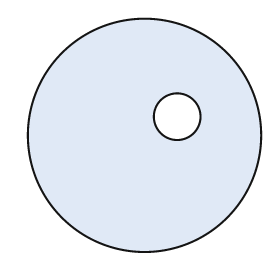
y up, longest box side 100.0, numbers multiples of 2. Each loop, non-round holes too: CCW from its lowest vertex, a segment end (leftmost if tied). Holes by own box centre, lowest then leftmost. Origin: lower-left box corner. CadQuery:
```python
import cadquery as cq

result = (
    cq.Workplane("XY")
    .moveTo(50.0, 50.0)
    .circle(50.0)
    .moveTo(64.0, 58.0)
    .circle(10.0)
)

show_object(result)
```